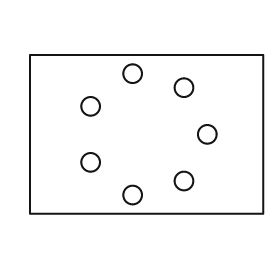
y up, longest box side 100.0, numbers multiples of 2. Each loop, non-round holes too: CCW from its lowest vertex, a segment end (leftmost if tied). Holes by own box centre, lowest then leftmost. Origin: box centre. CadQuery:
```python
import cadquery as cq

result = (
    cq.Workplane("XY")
    .moveTo(-50.0, -34.0)
    .lineTo(50.0, -34.0)
    .lineTo(50.0, 34.0)
    .lineTo(-50.0, 34.0)
    .close()
    .moveTo(-6.0, -26.0)
    .circle(4.0)
    .moveTo(16.0, -20.0)
    .circle(4.0)
    .moveTo(-24.0, -12.0)
    .circle(4.0)
    .moveTo(26.0, 0.0)
    .circle(4.0)
    .moveTo(-24.0, 12.0)
    .circle(4.0)
    .moveTo(16.0, 20.0)
    .circle(4.0)
    .moveTo(-6.0, 26.0)
    .circle(4.0)
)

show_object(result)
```